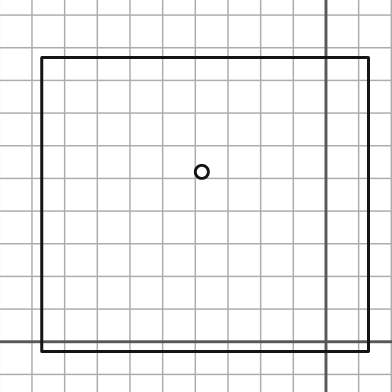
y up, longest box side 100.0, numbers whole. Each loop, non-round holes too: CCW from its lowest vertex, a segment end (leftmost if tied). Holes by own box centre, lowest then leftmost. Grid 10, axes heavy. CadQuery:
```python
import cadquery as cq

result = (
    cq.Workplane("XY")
    .moveTo(-87.0, -3.0)
    .lineTo(13.0, -3.0)
    .lineTo(13.0, 87.0)
    .lineTo(-87.0, 87.0)
    .close()
    .moveTo(-38.0, 52.0)
    .circle(2.0)
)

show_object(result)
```